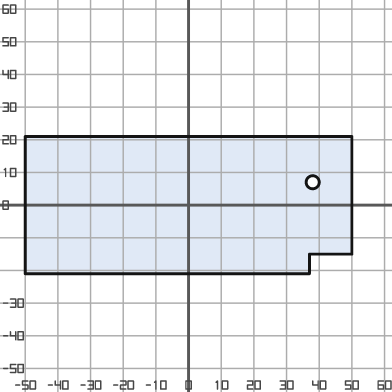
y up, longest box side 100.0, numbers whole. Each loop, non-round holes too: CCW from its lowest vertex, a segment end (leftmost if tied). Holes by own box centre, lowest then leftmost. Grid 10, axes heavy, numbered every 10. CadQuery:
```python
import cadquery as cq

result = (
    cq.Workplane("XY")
    .moveTo(-50.0, -21.0)
    .lineTo(37.0, -21.0)
    .lineTo(37.0, -15.0)
    .lineTo(50.0, -15.0)
    .lineTo(50.0, 21.0)
    .lineTo(-50.0, 21.0)
    .close()
    .moveTo(38.0, 7.0)
    .circle(2.0)
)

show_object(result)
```